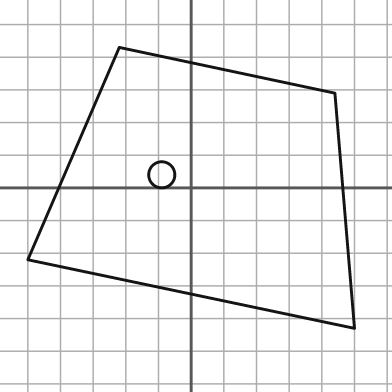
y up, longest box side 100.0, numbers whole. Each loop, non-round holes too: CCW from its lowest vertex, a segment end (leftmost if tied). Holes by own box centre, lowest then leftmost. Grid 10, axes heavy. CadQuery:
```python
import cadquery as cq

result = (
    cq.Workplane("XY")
    .moveTo(50.0, -43.0)
    .lineTo(44.0, 29.0)
    .lineTo(-22.0, 43.0)
    .lineTo(-50.0, -22.0)
    .close()
    .moveTo(-9.0, 4.0)
    .circle(4.0)
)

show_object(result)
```